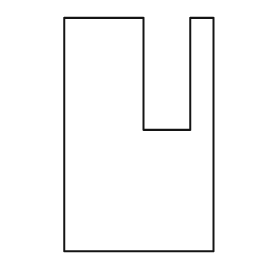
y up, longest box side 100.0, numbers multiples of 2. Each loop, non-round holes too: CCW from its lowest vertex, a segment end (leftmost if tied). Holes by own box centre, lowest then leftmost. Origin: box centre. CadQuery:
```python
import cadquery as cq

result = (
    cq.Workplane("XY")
    .moveTo(-32.0, -50.0)
    .lineTo(32.0, -50.0)
    .lineTo(32.0, 50.0)
    .lineTo(22.0, 50.0)
    .lineTo(22.0, 2.0)
    .lineTo(2.0, 2.0)
    .lineTo(2.0, 50.0)
    .lineTo(-32.0, 50.0)
    .close()
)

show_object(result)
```